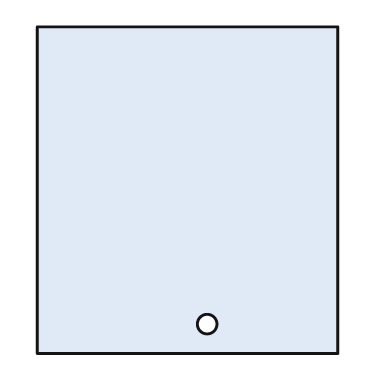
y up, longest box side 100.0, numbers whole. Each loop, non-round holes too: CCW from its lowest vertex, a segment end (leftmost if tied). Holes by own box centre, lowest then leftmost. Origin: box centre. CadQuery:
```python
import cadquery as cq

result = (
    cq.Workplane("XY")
    .moveTo(-46.0, -50.0)
    .lineTo(46.0, -50.0)
    .lineTo(46.0, 50.0)
    .lineTo(-46.0, 50.0)
    .close()
    .moveTo(6.0, -41.0)
    .circle(3.0)
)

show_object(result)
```